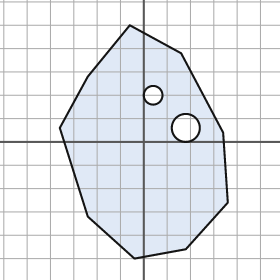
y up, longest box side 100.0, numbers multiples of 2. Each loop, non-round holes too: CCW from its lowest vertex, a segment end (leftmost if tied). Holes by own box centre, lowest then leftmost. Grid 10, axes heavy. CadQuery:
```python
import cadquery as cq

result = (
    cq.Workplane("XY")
    .moveTo(-4.0, -50.0)
    .lineTo(18.0, -46.0)
    .lineTo(36.0, -26.0)
    .lineTo(34.0, 4.0)
    .lineTo(16.0, 38.0)
    .lineTo(-6.0, 50.0)
    .lineTo(-24.0, 28.0)
    .lineTo(-36.0, 6.0)
    .lineTo(-24.0, -32.0)
    .close()
    .moveTo(18.0, 6.0)
    .circle(6.0)
    .moveTo(4.0, 20.0)
    .circle(4.0)
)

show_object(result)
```